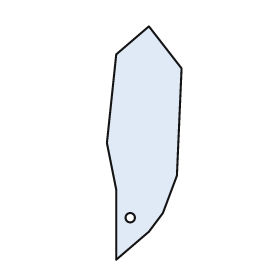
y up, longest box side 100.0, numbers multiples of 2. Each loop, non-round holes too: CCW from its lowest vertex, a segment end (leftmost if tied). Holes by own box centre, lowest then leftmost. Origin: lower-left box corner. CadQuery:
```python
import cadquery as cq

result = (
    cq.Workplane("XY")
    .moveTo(4.0, 0.0)
    .lineTo(18.0, 12.0)
    .lineTo(24.0, 20.0)
    .lineTo(30.0, 36.0)
    .lineTo(32.0, 82.0)
    .lineTo(18.0, 100.0)
    .lineTo(4.0, 88.0)
    .lineTo(0.0, 50.0)
    .lineTo(4.0, 30.0)
    .close()
    .moveTo(10.0, 18.0)
    .circle(2.0)
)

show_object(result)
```